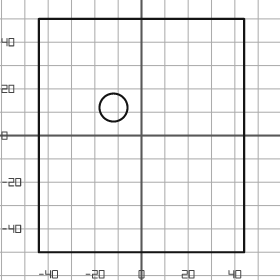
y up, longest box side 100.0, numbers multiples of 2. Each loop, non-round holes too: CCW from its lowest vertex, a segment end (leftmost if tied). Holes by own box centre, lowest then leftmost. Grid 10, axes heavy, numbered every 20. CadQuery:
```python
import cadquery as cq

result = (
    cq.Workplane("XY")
    .moveTo(-44.0, -50.0)
    .lineTo(44.0, -50.0)
    .lineTo(44.0, 50.0)
    .lineTo(-44.0, 50.0)
    .close()
    .moveTo(-12.0, 12.0)
    .circle(6.0)
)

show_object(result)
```